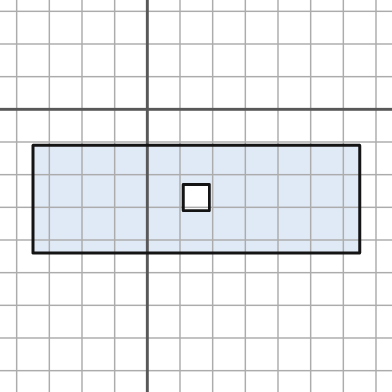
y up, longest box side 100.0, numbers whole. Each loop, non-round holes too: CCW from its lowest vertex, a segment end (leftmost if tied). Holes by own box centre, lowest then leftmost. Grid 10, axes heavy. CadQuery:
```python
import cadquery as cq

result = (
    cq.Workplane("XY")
    .moveTo(-35.0, -44.0)
    .lineTo(65.0, -44.0)
    .lineTo(65.0, -11.0)
    .lineTo(-35.0, -11.0)
    .close()
    .moveTo(11.0, -31.0)
    .lineTo(19.0, -31.0)
    .lineTo(19.0, -23.0)
    .lineTo(11.0, -23.0)
    .close()
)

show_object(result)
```